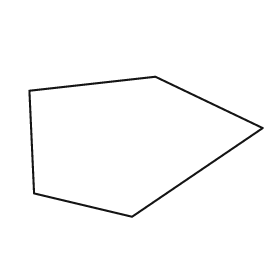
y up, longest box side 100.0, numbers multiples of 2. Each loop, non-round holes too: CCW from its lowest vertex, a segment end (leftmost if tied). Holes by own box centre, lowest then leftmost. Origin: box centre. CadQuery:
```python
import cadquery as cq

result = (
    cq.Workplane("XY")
    .moveTo(-6.0, -30.0)
    .lineTo(50.0, 8.0)
    .lineTo(4.0, 30.0)
    .lineTo(-50.0, 24.0)
    .lineTo(-48.0, -20.0)
    .close()
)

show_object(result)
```